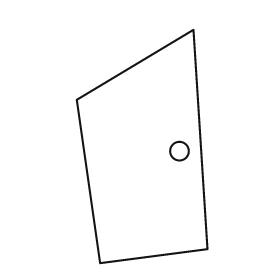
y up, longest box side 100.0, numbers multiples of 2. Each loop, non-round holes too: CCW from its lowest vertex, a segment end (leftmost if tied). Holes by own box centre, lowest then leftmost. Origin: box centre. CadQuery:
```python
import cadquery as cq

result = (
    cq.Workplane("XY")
    .moveTo(-18.0, -50.0)
    .lineTo(28.0, -44.0)
    .lineTo(22.0, 50.0)
    .lineTo(-28.0, 20.0)
    .close()
    .moveTo(16.0, -2.0)
    .circle(4.0)
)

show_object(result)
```